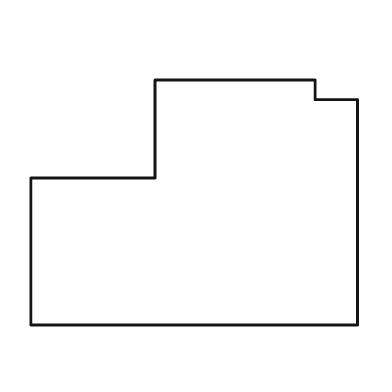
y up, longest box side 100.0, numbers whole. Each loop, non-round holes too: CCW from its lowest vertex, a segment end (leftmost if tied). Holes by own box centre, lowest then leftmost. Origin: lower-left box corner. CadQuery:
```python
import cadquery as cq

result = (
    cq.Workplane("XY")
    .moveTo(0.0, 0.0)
    .lineTo(100.0, 0.0)
    .lineTo(100.0, 69.0)
    .lineTo(87.0, 69.0)
    .lineTo(87.0, 75.0)
    .lineTo(38.0, 75.0)
    .lineTo(38.0, 45.0)
    .lineTo(0.0, 45.0)
    .close()
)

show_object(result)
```